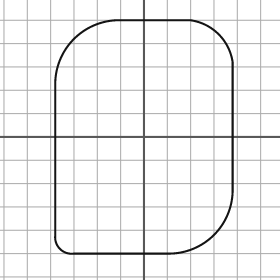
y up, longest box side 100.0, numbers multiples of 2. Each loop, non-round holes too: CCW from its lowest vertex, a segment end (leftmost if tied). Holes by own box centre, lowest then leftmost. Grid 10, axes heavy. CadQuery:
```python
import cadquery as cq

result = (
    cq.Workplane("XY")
    .moveTo(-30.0, -50.0)
    .lineTo(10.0, -50.0)
    .threePointArc((30.0, -42.0), (38.0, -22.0))
    .lineTo(38.0, 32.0)
    .threePointArc((32.0, 44.0), (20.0, 50.0))
    .lineTo(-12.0, 50.0)
    .threePointArc((-30.0, 42.0), (-38.0, 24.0))
    .lineTo(-38.0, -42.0)
    .threePointArc((-36.0, -48.0), (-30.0, -50.0))
    .close()
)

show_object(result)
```